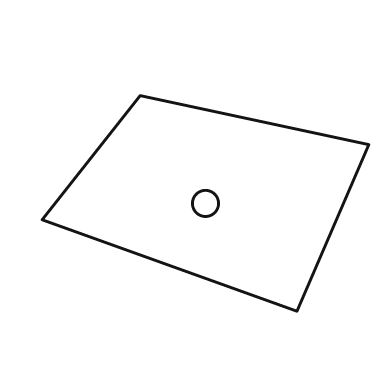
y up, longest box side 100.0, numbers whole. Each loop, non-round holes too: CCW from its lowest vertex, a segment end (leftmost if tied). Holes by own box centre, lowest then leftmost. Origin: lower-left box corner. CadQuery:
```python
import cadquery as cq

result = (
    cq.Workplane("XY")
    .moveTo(78.0, 0.0)
    .lineTo(100.0, 51.0)
    .lineTo(30.0, 66.0)
    .lineTo(0.0, 28.0)
    .close()
    .moveTo(50.0, 33.0)
    .circle(4.0)
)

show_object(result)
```